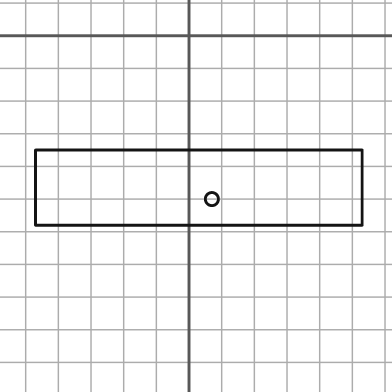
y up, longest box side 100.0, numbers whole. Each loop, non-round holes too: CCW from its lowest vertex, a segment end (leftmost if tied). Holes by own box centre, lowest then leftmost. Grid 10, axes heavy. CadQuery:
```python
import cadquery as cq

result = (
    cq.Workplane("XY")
    .moveTo(-47.0, -58.0)
    .lineTo(53.0, -58.0)
    .lineTo(53.0, -35.0)
    .lineTo(-47.0, -35.0)
    .close()
    .moveTo(7.0, -50.0)
    .circle(2.0)
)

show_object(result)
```